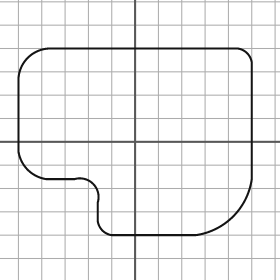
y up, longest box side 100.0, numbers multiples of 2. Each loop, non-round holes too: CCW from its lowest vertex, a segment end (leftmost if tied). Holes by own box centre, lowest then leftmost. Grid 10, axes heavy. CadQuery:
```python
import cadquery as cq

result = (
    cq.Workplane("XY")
    .moveTo(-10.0, -40.0)
    .lineTo(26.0, -40.0)
    .threePointArc((42.0, -32.0), (50.0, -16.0))
    .lineTo(50.0, 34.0)
    .threePointArc((48.0, 38.0), (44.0, 40.0))
    .lineTo(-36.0, 40.0)
    .threePointArc((-46.0, 36.0), (-50.0, 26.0))
    .lineTo(-50.0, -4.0)
    .threePointArc((-46.0, -12.0), (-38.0, -16.0))
    .lineTo(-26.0, -16.0)
    .threePointArc((-18.0, -18.0), (-16.0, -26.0))
    .lineTo(-16.0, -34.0)
    .threePointArc((-14.0, -38.0), (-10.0, -40.0))
    .close()
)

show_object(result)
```